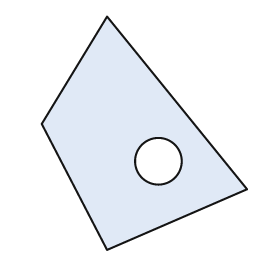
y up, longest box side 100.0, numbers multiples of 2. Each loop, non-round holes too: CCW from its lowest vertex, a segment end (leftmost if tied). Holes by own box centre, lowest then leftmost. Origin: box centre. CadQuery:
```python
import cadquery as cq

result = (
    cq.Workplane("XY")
    .moveTo(-16.0, -50.0)
    .lineTo(44.0, -24.0)
    .lineTo(-16.0, 50.0)
    .lineTo(-44.0, 4.0)
    .close()
    .moveTo(6.0, -12.0)
    .circle(10.0)
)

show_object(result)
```